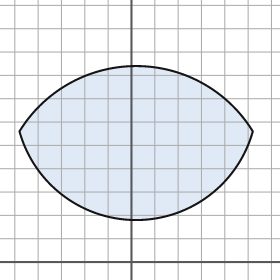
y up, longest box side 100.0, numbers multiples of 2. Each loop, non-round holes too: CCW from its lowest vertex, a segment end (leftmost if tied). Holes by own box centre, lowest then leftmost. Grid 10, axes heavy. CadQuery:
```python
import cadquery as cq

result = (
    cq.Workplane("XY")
    .moveTo(-48.0, 56.0)
    .threePointArc((2.0, 18.0), (52.0, 56.0))
    .threePointArc((2.0, 84.0), (-48.0, 56.0))
    .close()
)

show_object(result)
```